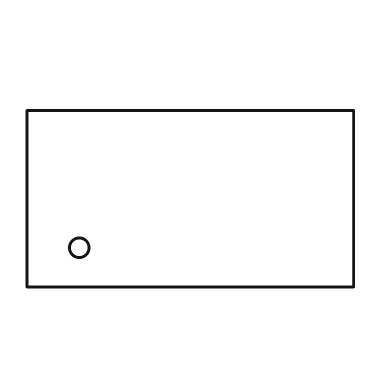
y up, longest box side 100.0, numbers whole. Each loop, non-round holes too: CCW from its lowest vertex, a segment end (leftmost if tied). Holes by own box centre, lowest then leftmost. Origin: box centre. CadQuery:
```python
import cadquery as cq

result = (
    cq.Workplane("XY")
    .moveTo(-50.0, -27.0)
    .lineTo(50.0, -27.0)
    .lineTo(50.0, 27.0)
    .lineTo(-50.0, 27.0)
    .close()
    .moveTo(-34.0, -15.0)
    .circle(3.0)
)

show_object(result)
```